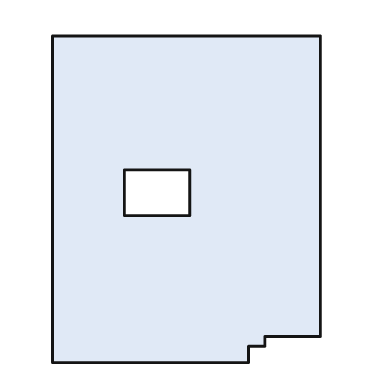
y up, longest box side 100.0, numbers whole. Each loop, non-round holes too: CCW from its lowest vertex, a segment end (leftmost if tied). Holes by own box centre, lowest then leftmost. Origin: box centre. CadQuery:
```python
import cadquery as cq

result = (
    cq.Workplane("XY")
    .moveTo(-41.0, -50.0)
    .lineTo(19.0, -50.0)
    .lineTo(19.0, -45.0)
    .lineTo(24.0, -45.0)
    .lineTo(24.0, -42.0)
    .lineTo(41.0, -42.0)
    .lineTo(41.0, 50.0)
    .lineTo(-41.0, 50.0)
    .close()
    .moveTo(-19.0, -5.0)
    .lineTo(1.0, -5.0)
    .lineTo(1.0, 9.0)
    .lineTo(-19.0, 9.0)
    .close()
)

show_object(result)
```